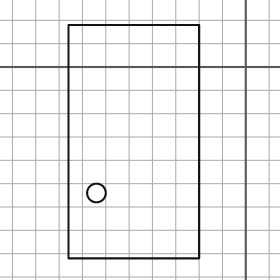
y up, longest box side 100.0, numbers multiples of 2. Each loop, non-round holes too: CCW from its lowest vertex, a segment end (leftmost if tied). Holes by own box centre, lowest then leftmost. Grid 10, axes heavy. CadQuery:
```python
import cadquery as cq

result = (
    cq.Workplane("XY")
    .moveTo(-76.0, -82.0)
    .lineTo(-20.0, -82.0)
    .lineTo(-20.0, 18.0)
    .lineTo(-76.0, 18.0)
    .close()
    .moveTo(-64.0, -54.0)
    .circle(4.0)
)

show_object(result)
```